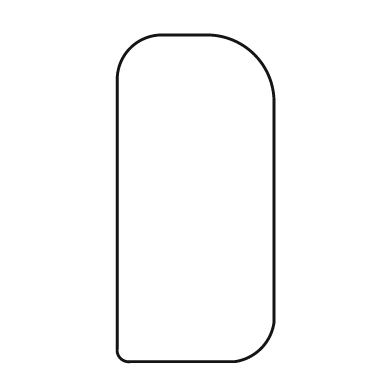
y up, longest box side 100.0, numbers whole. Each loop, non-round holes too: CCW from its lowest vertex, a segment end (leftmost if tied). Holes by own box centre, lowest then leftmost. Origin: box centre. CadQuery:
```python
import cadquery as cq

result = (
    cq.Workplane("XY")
    .moveTo(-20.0, -50.0)
    .lineTo(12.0, -50.0)
    .threePointArc((20.0, -46.0), (24.0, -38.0))
    .lineTo(24.0, 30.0)
    .threePointArc((18.0, 44.0), (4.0, 50.0))
    .lineTo(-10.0, 50.0)
    .threePointArc((-20.0, 46.0), (-24.0, 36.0))
    .lineTo(-24.0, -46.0)
    .threePointArc((-23.0, -49.0), (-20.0, -50.0))
    .close()
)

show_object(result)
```